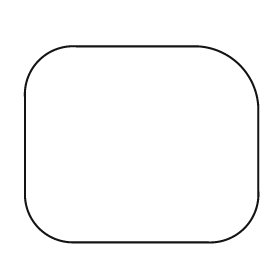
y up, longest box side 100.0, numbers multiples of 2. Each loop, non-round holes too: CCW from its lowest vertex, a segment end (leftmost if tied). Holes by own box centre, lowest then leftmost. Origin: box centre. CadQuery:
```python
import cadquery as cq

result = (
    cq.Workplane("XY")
    .moveTo(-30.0, -42.0)
    .lineTo(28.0, -42.0)
    .threePointArc((44.0, -36.0), (50.0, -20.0))
    .lineTo(50.0, 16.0)
    .threePointArc((42.0, 34.0), (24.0, 42.0))
    .lineTo(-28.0, 42.0)
    .threePointArc((-44.0, 36.0), (-50.0, 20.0))
    .lineTo(-50.0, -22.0)
    .threePointArc((-44.0, -36.0), (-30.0, -42.0))
    .close()
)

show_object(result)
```